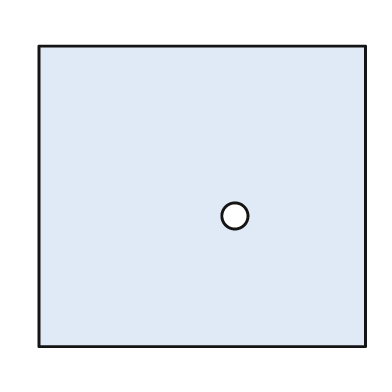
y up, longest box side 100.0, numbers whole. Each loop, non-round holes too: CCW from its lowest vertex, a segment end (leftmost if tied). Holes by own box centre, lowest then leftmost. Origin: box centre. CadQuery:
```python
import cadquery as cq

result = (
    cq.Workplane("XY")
    .moveTo(-50.0, -46.0)
    .lineTo(50.0, -46.0)
    .lineTo(50.0, 46.0)
    .lineTo(-50.0, 46.0)
    .close()
    .moveTo(10.0, -6.0)
    .circle(4.0)
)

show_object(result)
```